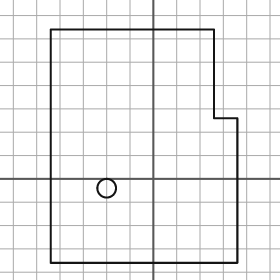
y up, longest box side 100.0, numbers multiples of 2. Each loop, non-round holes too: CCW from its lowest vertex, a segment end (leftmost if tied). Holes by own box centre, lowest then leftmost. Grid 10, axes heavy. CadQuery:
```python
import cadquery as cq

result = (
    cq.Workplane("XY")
    .moveTo(-44.0, -36.0)
    .lineTo(36.0, -36.0)
    .lineTo(36.0, 26.0)
    .lineTo(26.0, 26.0)
    .lineTo(26.0, 64.0)
    .lineTo(-44.0, 64.0)
    .close()
    .moveTo(-20.0, -4.0)
    .circle(4.0)
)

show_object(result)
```